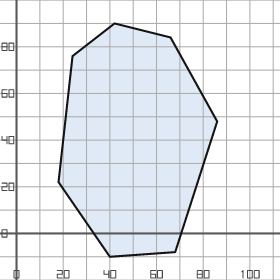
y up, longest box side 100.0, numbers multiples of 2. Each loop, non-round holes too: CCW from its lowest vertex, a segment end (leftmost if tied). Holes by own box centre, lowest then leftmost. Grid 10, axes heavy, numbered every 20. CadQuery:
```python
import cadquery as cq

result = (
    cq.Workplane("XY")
    .moveTo(40.0, -10.0)
    .lineTo(68.0, -8.0)
    .lineTo(86.0, 48.0)
    .lineTo(66.0, 84.0)
    .lineTo(42.0, 90.0)
    .lineTo(24.0, 76.0)
    .lineTo(18.0, 22.0)
    .close()
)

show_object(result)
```